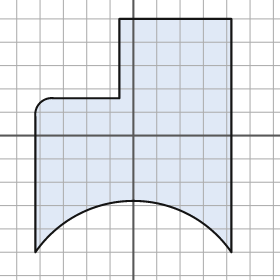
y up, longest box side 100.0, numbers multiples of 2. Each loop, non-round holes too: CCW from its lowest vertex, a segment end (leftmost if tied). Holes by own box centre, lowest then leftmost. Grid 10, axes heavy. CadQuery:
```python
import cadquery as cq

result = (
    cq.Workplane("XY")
    .moveTo(-42.0, -50.0)
    .threePointArc((0.0, -28.0), (42.0, -50.0))
    .lineTo(42.0, 50.0)
    .lineTo(-6.0, 50.0)
    .lineTo(-6.0, 16.0)
    .lineTo(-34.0, 16.0)
    .threePointArc((-40.0, 14.0), (-42.0, 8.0))
    .close()
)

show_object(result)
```